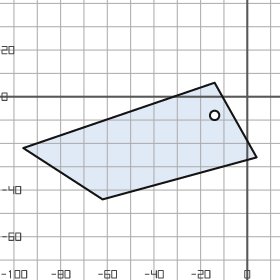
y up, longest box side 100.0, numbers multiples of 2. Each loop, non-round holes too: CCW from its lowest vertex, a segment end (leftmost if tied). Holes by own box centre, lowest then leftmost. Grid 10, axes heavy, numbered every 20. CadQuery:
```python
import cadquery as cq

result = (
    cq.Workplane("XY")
    .moveTo(-62.0, -44.0)
    .lineTo(4.0, -26.0)
    .lineTo(-14.0, 6.0)
    .lineTo(-96.0, -22.0)
    .close()
    .moveTo(-14.0, -8.0)
    .circle(2.0)
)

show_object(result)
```